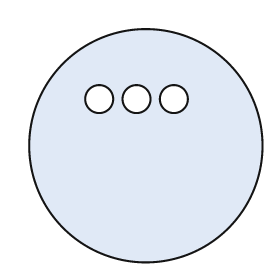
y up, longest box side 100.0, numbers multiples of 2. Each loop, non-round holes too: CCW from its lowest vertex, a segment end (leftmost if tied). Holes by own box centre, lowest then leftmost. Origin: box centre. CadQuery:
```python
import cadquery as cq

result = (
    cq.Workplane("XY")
    .moveTo(0.0, 0.0)
    .circle(50.0)
    .moveTo(-20.0, 20.0)
    .circle(6.0)
    .moveTo(-4.0, 20.0)
    .circle(6.0)
    .moveTo(12.0, 20.0)
    .circle(6.0)
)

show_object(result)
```